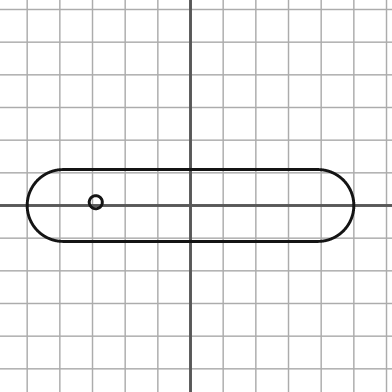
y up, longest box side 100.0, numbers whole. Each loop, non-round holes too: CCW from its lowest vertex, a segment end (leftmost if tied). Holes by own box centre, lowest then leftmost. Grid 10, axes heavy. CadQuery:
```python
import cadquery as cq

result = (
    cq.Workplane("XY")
    .moveTo(-39.0, -11.0)
    .lineTo(39.0, -11.0)
    .threePointArc((50.0, 0.0), (39.0, 11.0))
    .lineTo(-39.0, 11.0)
    .threePointArc((-50.0, 0.0), (-39.0, -11.0))
    .close()
    .moveTo(-29.0, 1.0)
    .circle(2.0)
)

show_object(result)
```